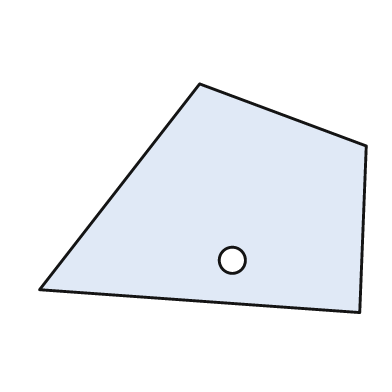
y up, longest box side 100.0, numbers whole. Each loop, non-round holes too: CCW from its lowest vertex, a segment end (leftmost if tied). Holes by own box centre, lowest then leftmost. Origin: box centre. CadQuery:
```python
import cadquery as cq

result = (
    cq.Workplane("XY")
    .moveTo(48.0, -35.0)
    .lineTo(50.0, 16.0)
    .lineTo(-1.0, 35.0)
    .lineTo(-50.0, -28.0)
    .close()
    .moveTo(9.0, -19.0)
    .circle(4.0)
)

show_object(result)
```